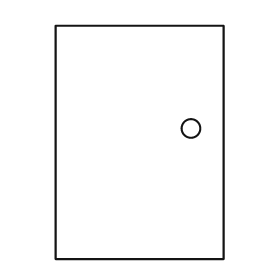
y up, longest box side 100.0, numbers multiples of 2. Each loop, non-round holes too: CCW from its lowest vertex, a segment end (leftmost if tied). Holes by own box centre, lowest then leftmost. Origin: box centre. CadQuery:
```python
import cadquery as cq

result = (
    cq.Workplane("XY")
    .moveTo(-36.0, -50.0)
    .lineTo(36.0, -50.0)
    .lineTo(36.0, 50.0)
    .lineTo(-36.0, 50.0)
    .close()
    .moveTo(22.0, 6.0)
    .circle(4.0)
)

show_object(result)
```